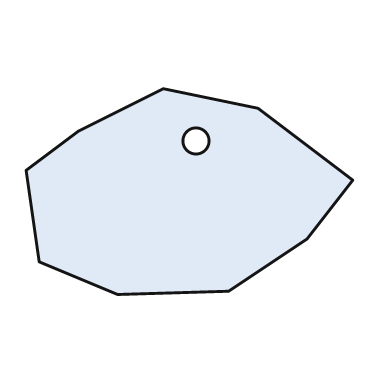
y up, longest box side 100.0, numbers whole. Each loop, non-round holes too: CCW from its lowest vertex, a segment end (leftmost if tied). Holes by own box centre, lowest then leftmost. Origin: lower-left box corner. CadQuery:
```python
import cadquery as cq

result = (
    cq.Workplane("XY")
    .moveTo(28.0, 0.0)
    .lineTo(62.0, 1.0)
    .lineTo(86.0, 17.0)
    .lineTo(100.0, 35.0)
    .lineTo(71.0, 57.0)
    .lineTo(42.0, 63.0)
    .lineTo(16.0, 50.0)
    .lineTo(0.0, 38.0)
    .lineTo(4.0, 10.0)
    .close()
    .moveTo(52.0, 47.0)
    .circle(4.0)
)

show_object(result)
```